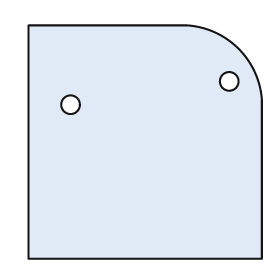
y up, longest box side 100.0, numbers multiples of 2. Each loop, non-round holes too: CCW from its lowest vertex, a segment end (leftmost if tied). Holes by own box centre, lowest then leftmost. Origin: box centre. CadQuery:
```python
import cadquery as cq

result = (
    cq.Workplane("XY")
    .moveTo(-50.0, -50.0)
    .lineTo(50.0, -50.0)
    .lineTo(50.0, 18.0)
    .threePointArc((40.0, 40.0), (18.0, 50.0))
    .lineTo(-50.0, 50.0)
    .close()
    .moveTo(-32.0, 16.0)
    .circle(4.0)
    .moveTo(36.0, 26.0)
    .circle(4.0)
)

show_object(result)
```